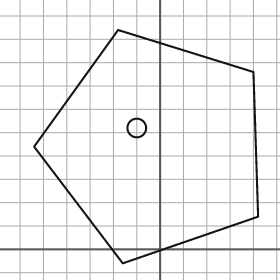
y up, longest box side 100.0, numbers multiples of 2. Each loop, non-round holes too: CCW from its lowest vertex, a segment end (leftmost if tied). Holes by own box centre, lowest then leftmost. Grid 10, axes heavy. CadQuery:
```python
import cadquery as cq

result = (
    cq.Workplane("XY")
    .moveTo(-16.0, -6.0)
    .lineTo(42.0, 14.0)
    .lineTo(40.0, 76.0)
    .lineTo(-18.0, 94.0)
    .lineTo(-54.0, 44.0)
    .close()
    .moveTo(-10.0, 52.0)
    .circle(4.0)
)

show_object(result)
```